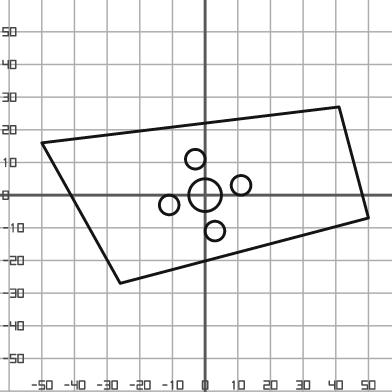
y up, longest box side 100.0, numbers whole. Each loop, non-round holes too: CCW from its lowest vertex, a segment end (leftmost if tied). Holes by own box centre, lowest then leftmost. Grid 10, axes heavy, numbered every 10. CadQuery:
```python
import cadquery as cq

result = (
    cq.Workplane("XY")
    .moveTo(-26.0, -27.0)
    .lineTo(50.0, -7.0)
    .lineTo(41.0, 27.0)
    .lineTo(-50.0, 16.0)
    .close()
    .moveTo(3.0, -11.0)
    .circle(3.0)
    .moveTo(-11.0, -3.0)
    .circle(3.0)
    .moveTo(0.0, 0.0)
    .circle(5.0)
    .moveTo(11.0, 3.0)
    .circle(3.0)
    .moveTo(-3.0, 11.0)
    .circle(3.0)
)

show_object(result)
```